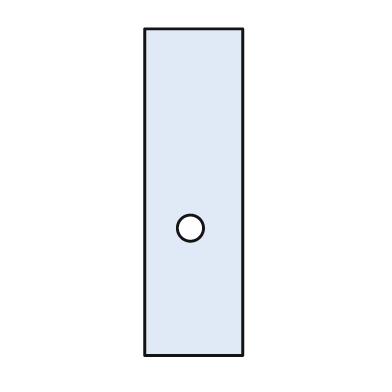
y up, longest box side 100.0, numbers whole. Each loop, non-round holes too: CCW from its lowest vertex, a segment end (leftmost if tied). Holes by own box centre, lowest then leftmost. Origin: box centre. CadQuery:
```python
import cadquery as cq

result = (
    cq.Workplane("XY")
    .moveTo(-15.0, -50.0)
    .lineTo(15.0, -50.0)
    .lineTo(15.0, 50.0)
    .lineTo(-15.0, 50.0)
    .close()
    .moveTo(-1.0, -11.0)
    .circle(4.0)
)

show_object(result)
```